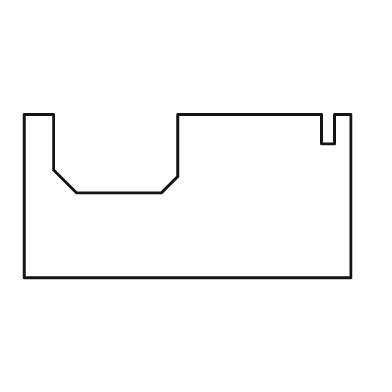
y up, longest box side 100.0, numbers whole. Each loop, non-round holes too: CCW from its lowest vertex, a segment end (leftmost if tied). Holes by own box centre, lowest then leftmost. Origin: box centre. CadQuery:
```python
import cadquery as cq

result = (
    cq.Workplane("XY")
    .moveTo(-50.0, -25.0)
    .lineTo(50.0, -25.0)
    .lineTo(50.0, 25.0)
    .lineTo(45.0, 25.0)
    .lineTo(45.0, 16.0)
    .lineTo(41.0, 16.0)
    .lineTo(41.0, 25.0)
    .lineTo(-3.0, 25.0)
    .lineTo(-3.0, 6.0)
    .lineTo(-8.0, 1.0)
    .lineTo(-34.0, 1.0)
    .lineTo(-41.0, 8.0)
    .lineTo(-41.0, 25.0)
    .lineTo(-50.0, 25.0)
    .close()
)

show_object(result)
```